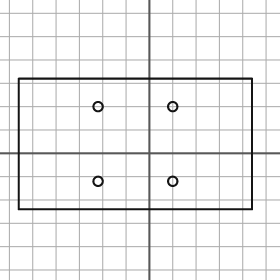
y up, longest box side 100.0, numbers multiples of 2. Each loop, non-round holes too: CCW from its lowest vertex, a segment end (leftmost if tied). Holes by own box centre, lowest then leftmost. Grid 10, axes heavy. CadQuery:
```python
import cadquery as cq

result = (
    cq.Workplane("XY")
    .moveTo(-56.0, -24.0)
    .lineTo(44.0, -24.0)
    .lineTo(44.0, 32.0)
    .lineTo(-56.0, 32.0)
    .close()
    .moveTo(-22.0, -12.0)
    .circle(2.0)
    .moveTo(10.0, -12.0)
    .circle(2.0)
    .moveTo(-22.0, 20.0)
    .circle(2.0)
    .moveTo(10.0, 20.0)
    .circle(2.0)
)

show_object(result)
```